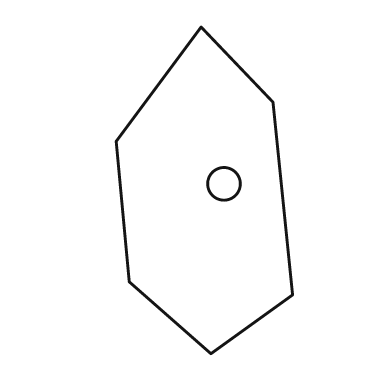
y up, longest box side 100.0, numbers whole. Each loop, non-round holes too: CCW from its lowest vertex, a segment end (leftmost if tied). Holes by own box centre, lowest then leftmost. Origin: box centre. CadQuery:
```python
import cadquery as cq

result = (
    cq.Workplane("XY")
    .moveTo(2.0, -50.0)
    .lineTo(27.0, -32.0)
    .lineTo(21.0, 27.0)
    .lineTo(-1.0, 50.0)
    .lineTo(-27.0, 15.0)
    .lineTo(-23.0, -28.0)
    .close()
    .moveTo(6.0, 2.0)
    .circle(5.0)
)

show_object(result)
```